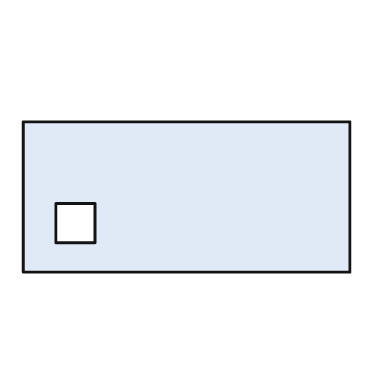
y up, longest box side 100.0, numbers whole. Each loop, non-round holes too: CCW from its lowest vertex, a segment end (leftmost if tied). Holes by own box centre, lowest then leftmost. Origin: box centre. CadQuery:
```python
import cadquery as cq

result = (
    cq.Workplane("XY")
    .moveTo(-50.0, -23.0)
    .lineTo(50.0, -23.0)
    .lineTo(50.0, 23.0)
    .lineTo(-50.0, 23.0)
    .close()
    .moveTo(-40.0, -14.0)
    .lineTo(-28.0, -14.0)
    .lineTo(-28.0, -2.0)
    .lineTo(-40.0, -2.0)
    .close()
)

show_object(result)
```